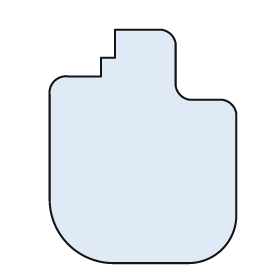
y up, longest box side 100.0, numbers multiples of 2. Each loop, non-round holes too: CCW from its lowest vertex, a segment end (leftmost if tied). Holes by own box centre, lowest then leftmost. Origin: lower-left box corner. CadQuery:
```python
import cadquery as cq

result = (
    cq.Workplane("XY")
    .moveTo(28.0, 0.0)
    .lineTo(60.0, 0.0)
    .threePointArc((74.0, 6.0), (80.0, 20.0))
    .lineTo(80.0, 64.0)
    .threePointArc((78.0, 68.0), (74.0, 70.0))
    .lineTo(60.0, 70.0)
    .threePointArc((56.0, 72.0), (54.0, 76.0))
    .lineTo(54.0, 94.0)
    .threePointArc((52.0, 98.0), (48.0, 100.0))
    .lineTo(28.0, 100.0)
    .lineTo(28.0, 88.0)
    .lineTo(22.0, 88.0)
    .lineTo(22.0, 80.0)
    .lineTo(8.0, 80.0)
    .threePointArc((2.0, 78.0), (0.0, 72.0))
    .lineTo(0.0, 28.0)
    .threePointArc((8.0, 8.0), (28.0, 0.0))
    .close()
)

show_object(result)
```